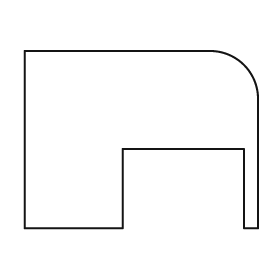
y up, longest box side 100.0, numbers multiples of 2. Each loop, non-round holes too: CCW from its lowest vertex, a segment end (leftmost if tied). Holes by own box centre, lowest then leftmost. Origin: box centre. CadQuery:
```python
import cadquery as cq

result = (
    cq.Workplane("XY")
    .moveTo(-50.0, -38.0)
    .lineTo(-8.0, -38.0)
    .lineTo(-8.0, -4.0)
    .lineTo(44.0, -4.0)
    .lineTo(44.0, -38.0)
    .lineTo(50.0, -38.0)
    .lineTo(50.0, 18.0)
    .threePointArc((44.0, 32.0), (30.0, 38.0))
    .lineTo(-50.0, 38.0)
    .close()
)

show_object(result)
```